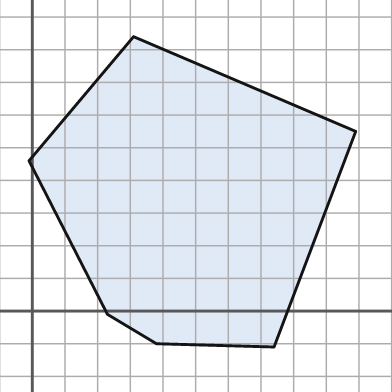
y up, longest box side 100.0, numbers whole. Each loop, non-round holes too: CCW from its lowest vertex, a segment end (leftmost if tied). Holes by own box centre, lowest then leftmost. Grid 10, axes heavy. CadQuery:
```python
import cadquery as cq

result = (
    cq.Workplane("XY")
    .moveTo(74.0, -11.0)
    .lineTo(99.0, 55.0)
    .lineTo(31.0, 84.0)
    .lineTo(-1.0, 46.0)
    .lineTo(23.0, -1.0)
    .lineTo(38.0, -10.0)
    .close()
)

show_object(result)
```